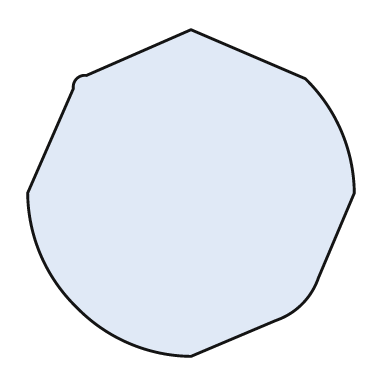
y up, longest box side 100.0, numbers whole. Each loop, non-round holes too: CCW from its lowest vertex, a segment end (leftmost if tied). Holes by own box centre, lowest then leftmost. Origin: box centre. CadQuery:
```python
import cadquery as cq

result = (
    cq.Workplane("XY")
    .moveTo(0.0, -50.0)
    .lineTo(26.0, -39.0)
    .threePointArc((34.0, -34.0), (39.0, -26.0))
    .lineTo(50.0, 0.0)
    .threePointArc((46.0, 19.0), (35.0, 35.0))
    .lineTo(0.0, 50.0)
    .lineTo(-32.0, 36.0)
    .threePointArc((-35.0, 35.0), (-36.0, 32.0))
    .lineTo(-50.0, 0.0)
    .threePointArc((-46.0, -19.0), (-35.0, -35.0))
    .threePointArc((-19.0, -46.0), (0.0, -50.0))
    .close()
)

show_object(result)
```